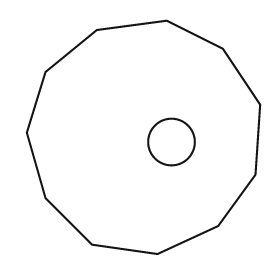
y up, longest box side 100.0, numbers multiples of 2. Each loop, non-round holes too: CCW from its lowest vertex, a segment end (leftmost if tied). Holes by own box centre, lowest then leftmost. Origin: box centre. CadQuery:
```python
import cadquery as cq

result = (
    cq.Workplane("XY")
    .moveTo(6.0, -50.0)
    .lineTo(32.0, -38.0)
    .lineTo(48.0, -16.0)
    .lineTo(50.0, 14.0)
    .lineTo(34.0, 38.0)
    .lineTo(10.0, 50.0)
    .lineTo(-20.0, 46.0)
    .lineTo(-42.0, 28.0)
    .lineTo(-50.0, 2.0)
    .lineTo(-42.0, -26.0)
    .lineTo(-22.0, -46.0)
    .close()
    .moveTo(12.0, -2.0)
    .circle(10.0)
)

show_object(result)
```